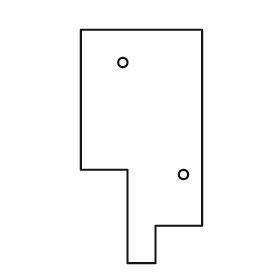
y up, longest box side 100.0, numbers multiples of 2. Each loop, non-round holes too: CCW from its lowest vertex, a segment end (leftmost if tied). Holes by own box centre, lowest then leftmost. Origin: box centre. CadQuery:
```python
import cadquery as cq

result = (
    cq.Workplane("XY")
    .moveTo(-6.0, -50.0)
    .lineTo(6.0, -50.0)
    .lineTo(6.0, -34.0)
    .lineTo(26.0, -34.0)
    .lineTo(26.0, 50.0)
    .lineTo(-26.0, 50.0)
    .lineTo(-26.0, -10.0)
    .lineTo(-6.0, -10.0)
    .close()
    .moveTo(18.0, -12.0)
    .circle(2.0)
    .moveTo(-8.0, 36.0)
    .circle(2.0)
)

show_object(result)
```